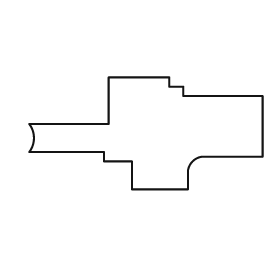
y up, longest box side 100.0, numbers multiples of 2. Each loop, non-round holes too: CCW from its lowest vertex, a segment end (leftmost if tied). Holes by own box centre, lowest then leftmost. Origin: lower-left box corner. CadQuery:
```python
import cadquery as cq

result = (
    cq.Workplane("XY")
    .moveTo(44.0, 0.0)
    .lineTo(68.0, 0.0)
    .lineTo(68.0, 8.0)
    .threePointArc((70.0, 12.0), (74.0, 14.0))
    .lineTo(100.0, 14.0)
    .lineTo(100.0, 40.0)
    .lineTo(66.0, 40.0)
    .lineTo(66.0, 44.0)
    .lineTo(60.0, 44.0)
    .lineTo(60.0, 48.0)
    .lineTo(34.0, 48.0)
    .lineTo(34.0, 28.0)
    .lineTo(0.0, 28.0)
    .threePointArc((2.0, 22.0), (0.0, 16.0))
    .lineTo(32.0, 16.0)
    .lineTo(32.0, 12.0)
    .lineTo(44.0, 12.0)
    .close()
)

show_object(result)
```